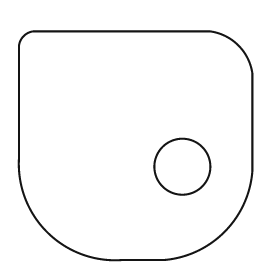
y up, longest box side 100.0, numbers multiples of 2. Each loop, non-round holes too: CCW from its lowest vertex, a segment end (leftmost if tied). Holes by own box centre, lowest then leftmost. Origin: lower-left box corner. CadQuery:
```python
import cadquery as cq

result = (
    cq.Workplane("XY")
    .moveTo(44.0, 0.0)
    .lineTo(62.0, 0.0)
    .threePointArc((88.0, 12.0), (100.0, 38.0))
    .lineTo(100.0, 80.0)
    .threePointArc((94.0, 92.0), (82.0, 98.0))
    .lineTo(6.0, 98.0)
    .threePointArc((2.0, 96.0), (0.0, 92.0))
    .lineTo(0.0, 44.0)
    .threePointArc((12.0, 12.0), (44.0, 0.0))
    .close()
    .moveTo(70.0, 40.0)
    .circle(12.0)
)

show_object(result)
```